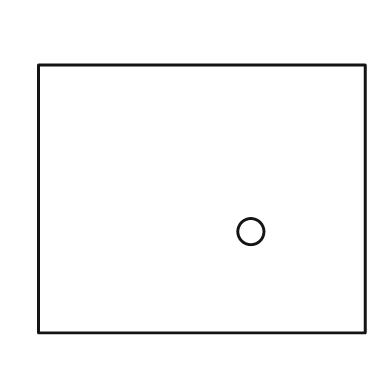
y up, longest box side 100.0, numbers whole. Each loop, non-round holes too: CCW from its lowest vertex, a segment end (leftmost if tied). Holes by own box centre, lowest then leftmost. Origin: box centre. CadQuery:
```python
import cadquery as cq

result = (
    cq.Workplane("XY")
    .moveTo(-50.0, -41.0)
    .lineTo(50.0, -41.0)
    .lineTo(50.0, 41.0)
    .lineTo(-50.0, 41.0)
    .close()
    .moveTo(15.0, -10.0)
    .circle(4.0)
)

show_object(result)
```